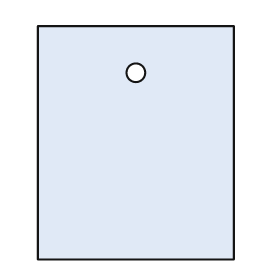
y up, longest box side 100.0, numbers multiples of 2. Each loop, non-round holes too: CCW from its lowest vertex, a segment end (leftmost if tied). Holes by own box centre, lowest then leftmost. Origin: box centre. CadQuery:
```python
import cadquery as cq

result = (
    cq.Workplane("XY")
    .moveTo(-42.0, -50.0)
    .lineTo(42.0, -50.0)
    .lineTo(42.0, 50.0)
    .lineTo(-42.0, 50.0)
    .close()
    .moveTo(0.0, 30.0)
    .circle(4.0)
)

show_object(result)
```